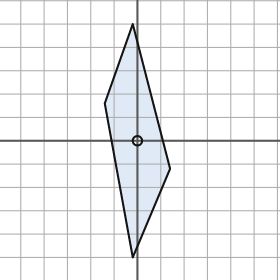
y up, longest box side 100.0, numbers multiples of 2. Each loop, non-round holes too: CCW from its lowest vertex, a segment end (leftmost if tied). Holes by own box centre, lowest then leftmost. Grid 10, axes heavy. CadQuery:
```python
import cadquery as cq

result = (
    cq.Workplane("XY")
    .moveTo(-2.0, -50.0)
    .lineTo(14.0, -12.0)
    .lineTo(-2.0, 50.0)
    .lineTo(-14.0, 16.0)
    .close()
    .moveTo(0.0, 0.0)
    .circle(2.0)
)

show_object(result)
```